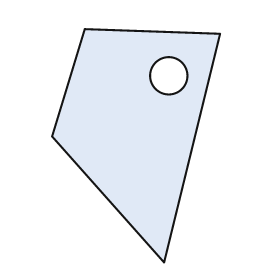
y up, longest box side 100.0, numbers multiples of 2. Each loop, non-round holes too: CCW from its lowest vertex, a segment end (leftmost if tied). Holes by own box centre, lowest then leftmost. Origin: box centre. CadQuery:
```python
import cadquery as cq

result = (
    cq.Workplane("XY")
    .moveTo(12.0, -50.0)
    .lineTo(36.0, 48.0)
    .lineTo(-22.0, 50.0)
    .lineTo(-36.0, 4.0)
    .close()
    .moveTo(14.0, 30.0)
    .circle(8.0)
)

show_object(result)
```